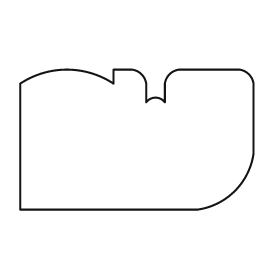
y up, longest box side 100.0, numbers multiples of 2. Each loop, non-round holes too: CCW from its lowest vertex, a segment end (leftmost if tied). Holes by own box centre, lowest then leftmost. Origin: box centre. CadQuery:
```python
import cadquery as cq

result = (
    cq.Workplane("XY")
    .moveTo(-50.0, -30.0)
    .lineTo(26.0, -30.0)
    .threePointArc((42.0, -22.0), (50.0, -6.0))
    .lineTo(50.0, 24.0)
    .threePointArc((48.0, 28.0), (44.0, 30.0))
    .lineTo(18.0, 30.0)
    .threePointArc((14.0, 28.0), (12.0, 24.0))
    .lineTo(12.0, 16.0)
    .threePointArc((8.0, 18.0), (4.0, 16.0))
    .lineTo(4.0, 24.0)
    .threePointArc((2.0, 28.0), (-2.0, 30.0))
    .lineTo(-10.0, 30.0)
    .lineTo(-10.0, 24.0)
    .threePointArc((-30.0, 30.0), (-50.0, 24.0))
    .close()
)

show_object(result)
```